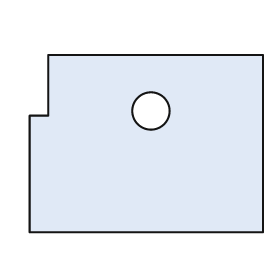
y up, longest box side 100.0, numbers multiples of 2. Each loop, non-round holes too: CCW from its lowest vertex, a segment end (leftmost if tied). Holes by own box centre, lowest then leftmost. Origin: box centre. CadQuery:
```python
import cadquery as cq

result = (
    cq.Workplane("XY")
    .moveTo(-50.0, -38.0)
    .lineTo(50.0, -38.0)
    .lineTo(50.0, 38.0)
    .lineTo(-42.0, 38.0)
    .lineTo(-42.0, 12.0)
    .lineTo(-50.0, 12.0)
    .close()
    .moveTo(2.0, 14.0)
    .circle(8.0)
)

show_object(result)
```